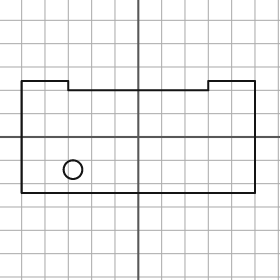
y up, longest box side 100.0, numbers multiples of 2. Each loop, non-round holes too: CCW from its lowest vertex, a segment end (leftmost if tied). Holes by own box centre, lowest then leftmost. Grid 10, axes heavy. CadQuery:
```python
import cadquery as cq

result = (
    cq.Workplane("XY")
    .moveTo(-50.0, -24.0)
    .lineTo(50.0, -24.0)
    .lineTo(50.0, 24.0)
    .lineTo(30.0, 24.0)
    .lineTo(30.0, 20.0)
    .lineTo(-30.0, 20.0)
    .lineTo(-30.0, 24.0)
    .lineTo(-50.0, 24.0)
    .close()
    .moveTo(-28.0, -14.0)
    .circle(4.0)
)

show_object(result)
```